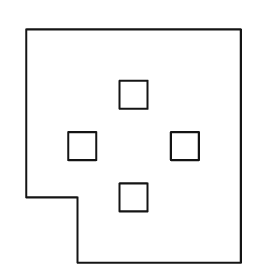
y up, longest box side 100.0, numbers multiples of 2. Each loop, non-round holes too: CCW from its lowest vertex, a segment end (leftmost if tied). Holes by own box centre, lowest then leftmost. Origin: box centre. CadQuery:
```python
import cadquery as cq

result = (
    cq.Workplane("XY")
    .moveTo(-24.0, -50.0)
    .lineTo(46.0, -50.0)
    .lineTo(46.0, 50.0)
    .lineTo(-46.0, 50.0)
    .lineTo(-46.0, -22.0)
    .lineTo(-24.0, -22.0)
    .close()
    .moveTo(-6.0, -28.0)
    .lineTo(6.0, -28.0)
    .lineTo(6.0, -16.0)
    .lineTo(-6.0, -16.0)
    .close()
    .moveTo(-28.0, -6.0)
    .lineTo(-16.0, -6.0)
    .lineTo(-16.0, 6.0)
    .lineTo(-28.0, 6.0)
    .close()
    .moveTo(16.0, -6.0)
    .lineTo(28.0, -6.0)
    .lineTo(28.0, 6.0)
    .lineTo(16.0, 6.0)
    .close()
    .moveTo(-6.0, 16.0)
    .lineTo(6.0, 16.0)
    .lineTo(6.0, 28.0)
    .lineTo(-6.0, 28.0)
    .close()
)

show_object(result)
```